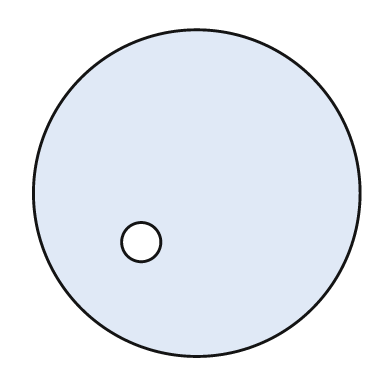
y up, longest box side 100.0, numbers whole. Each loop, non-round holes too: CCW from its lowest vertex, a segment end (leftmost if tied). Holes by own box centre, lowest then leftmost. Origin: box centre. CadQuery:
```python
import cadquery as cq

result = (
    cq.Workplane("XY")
    .moveTo(0.0, 0.0)
    .circle(50.0)
    .moveTo(-17.0, -15.0)
    .circle(6.0)
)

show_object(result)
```